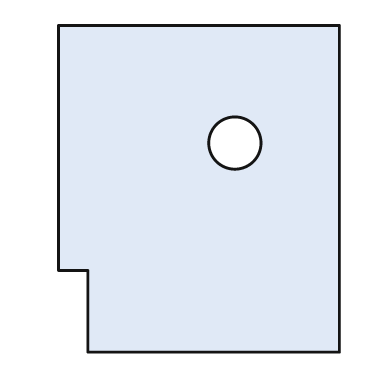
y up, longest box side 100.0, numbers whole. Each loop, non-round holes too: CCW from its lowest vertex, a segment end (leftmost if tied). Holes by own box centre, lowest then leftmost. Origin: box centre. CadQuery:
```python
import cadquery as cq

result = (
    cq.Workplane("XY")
    .moveTo(-34.0, -50.0)
    .lineTo(43.0, -50.0)
    .lineTo(43.0, 50.0)
    .lineTo(-43.0, 50.0)
    .lineTo(-43.0, -25.0)
    .lineTo(-34.0, -25.0)
    .close()
    .moveTo(11.0, 14.0)
    .circle(8.0)
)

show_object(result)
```